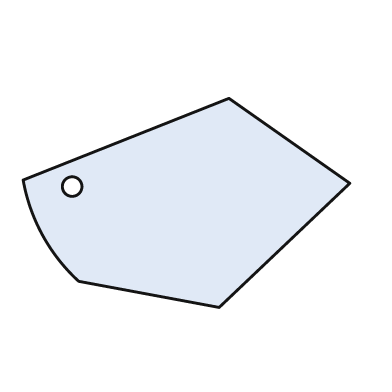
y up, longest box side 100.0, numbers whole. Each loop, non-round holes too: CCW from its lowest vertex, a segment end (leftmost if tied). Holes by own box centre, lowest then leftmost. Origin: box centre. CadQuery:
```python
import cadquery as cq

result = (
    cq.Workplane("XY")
    .moveTo(10.0, -32.0)
    .lineTo(50.0, 6.0)
    .lineTo(13.0, 32.0)
    .lineTo(-50.0, 7.0)
    .threePointArc((-44.0, -10.0), (-33.0, -24.0))
    .close()
    .moveTo(-35.0, 5.0)
    .circle(3.0)
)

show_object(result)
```